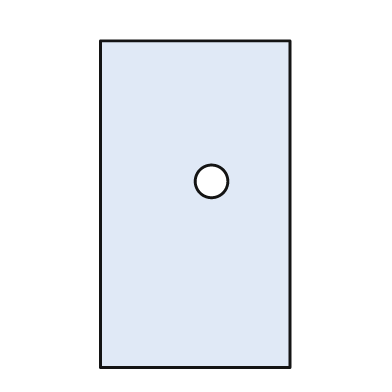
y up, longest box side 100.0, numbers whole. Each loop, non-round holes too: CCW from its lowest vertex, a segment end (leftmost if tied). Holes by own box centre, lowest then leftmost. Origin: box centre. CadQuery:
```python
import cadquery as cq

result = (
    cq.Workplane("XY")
    .moveTo(-29.0, -50.0)
    .lineTo(29.0, -50.0)
    .lineTo(29.0, 50.0)
    .lineTo(-29.0, 50.0)
    .close()
    .moveTo(5.0, 7.0)
    .circle(5.0)
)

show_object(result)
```